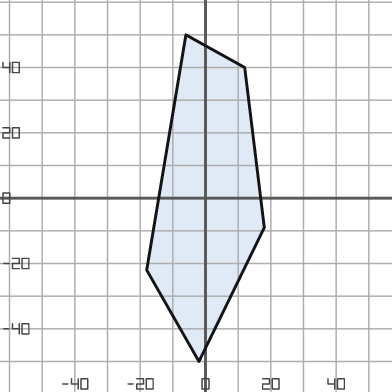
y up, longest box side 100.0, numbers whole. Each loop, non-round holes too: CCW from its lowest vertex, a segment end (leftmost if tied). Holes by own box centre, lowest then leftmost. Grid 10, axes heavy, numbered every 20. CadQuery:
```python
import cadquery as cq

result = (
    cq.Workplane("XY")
    .moveTo(-2.0, -50.0)
    .lineTo(18.0, -9.0)
    .lineTo(12.0, 40.0)
    .lineTo(-6.0, 50.0)
    .lineTo(-18.0, -22.0)
    .close()
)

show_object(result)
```